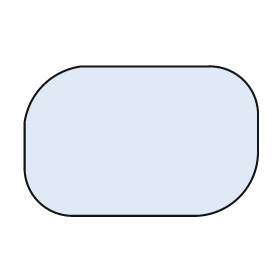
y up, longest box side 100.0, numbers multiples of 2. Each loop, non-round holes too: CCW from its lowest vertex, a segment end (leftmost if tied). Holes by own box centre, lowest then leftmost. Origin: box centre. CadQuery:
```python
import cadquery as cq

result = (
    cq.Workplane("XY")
    .moveTo(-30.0, -32.0)
    .lineTo(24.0, -32.0)
    .threePointArc((42.0, -24.0), (50.0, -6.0))
    .lineTo(50.0, 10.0)
    .threePointArc((44.0, 26.0), (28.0, 32.0))
    .lineTo(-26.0, 32.0)
    .threePointArc((-42.0, 24.0), (-50.0, 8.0))
    .lineTo(-50.0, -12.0)
    .threePointArc((-44.0, -26.0), (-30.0, -32.0))
    .close()
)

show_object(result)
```